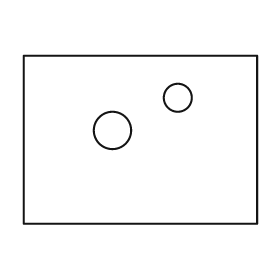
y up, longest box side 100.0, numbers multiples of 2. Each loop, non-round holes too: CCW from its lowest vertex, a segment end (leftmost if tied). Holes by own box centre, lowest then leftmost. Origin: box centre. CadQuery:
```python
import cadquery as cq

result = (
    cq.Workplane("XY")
    .moveTo(-50.0, -36.0)
    .lineTo(50.0, -36.0)
    .lineTo(50.0, 36.0)
    .lineTo(-50.0, 36.0)
    .close()
    .moveTo(-12.0, 4.0)
    .circle(8.0)
    .moveTo(16.0, 18.0)
    .circle(6.0)
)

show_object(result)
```